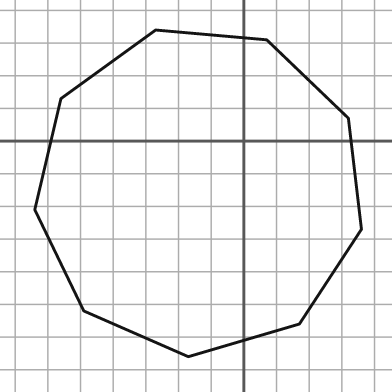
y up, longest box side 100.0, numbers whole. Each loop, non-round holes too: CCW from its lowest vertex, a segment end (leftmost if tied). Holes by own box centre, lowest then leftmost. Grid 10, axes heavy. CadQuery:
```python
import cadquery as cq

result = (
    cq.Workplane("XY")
    .moveTo(-17.0, -66.0)
    .lineTo(17.0, -56.0)
    .lineTo(36.0, -27.0)
    .lineTo(32.0, 7.0)
    .lineTo(7.0, 31.0)
    .lineTo(-27.0, 34.0)
    .lineTo(-56.0, 13.0)
    .lineTo(-64.0, -21.0)
    .lineTo(-49.0, -52.0)
    .close()
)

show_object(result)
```